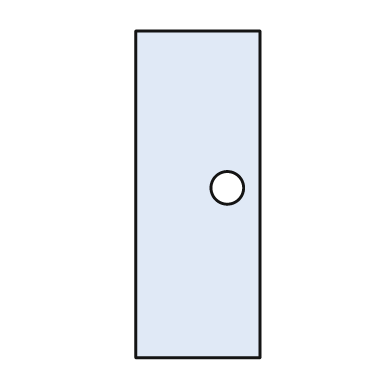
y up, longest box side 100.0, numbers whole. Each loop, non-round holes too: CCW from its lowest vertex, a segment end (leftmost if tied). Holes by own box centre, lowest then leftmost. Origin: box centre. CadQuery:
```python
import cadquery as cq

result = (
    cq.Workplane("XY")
    .moveTo(-19.0, -50.0)
    .lineTo(19.0, -50.0)
    .lineTo(19.0, 50.0)
    .lineTo(-19.0, 50.0)
    .close()
    .moveTo(9.0, 2.0)
    .circle(5.0)
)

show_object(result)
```